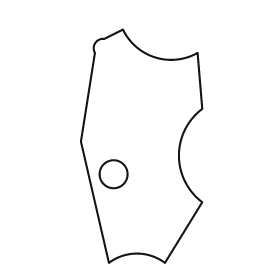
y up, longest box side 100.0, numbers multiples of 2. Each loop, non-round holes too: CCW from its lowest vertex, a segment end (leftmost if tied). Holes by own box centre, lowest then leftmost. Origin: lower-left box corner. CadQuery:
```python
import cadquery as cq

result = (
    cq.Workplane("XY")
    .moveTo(12.0, 0.0)
    .threePointArc((24.0, 4.0), (36.0, 0.0))
    .lineTo(52.0, 26.0)
    .threePointArc((42.0, 46.0), (52.0, 66.0))
    .lineTo(50.0, 90.0)
    .threePointArc((32.0, 88.0), (18.0, 100.0))
    .lineTo(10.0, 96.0)
    .threePointArc((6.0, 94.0), (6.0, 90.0))
    .lineTo(0.0, 52.0)
    .close()
    .moveTo(14.0, 38.0)
    .circle(6.0)
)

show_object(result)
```